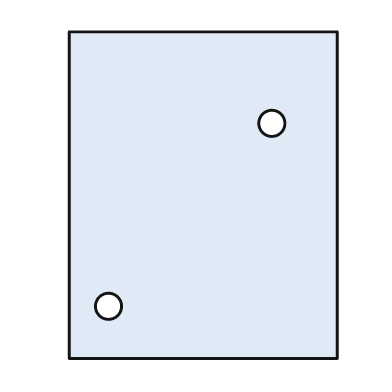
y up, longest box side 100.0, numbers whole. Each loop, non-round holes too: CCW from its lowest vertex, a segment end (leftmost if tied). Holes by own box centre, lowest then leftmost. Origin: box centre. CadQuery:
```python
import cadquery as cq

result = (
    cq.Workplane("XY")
    .moveTo(-41.0, -50.0)
    .lineTo(41.0, -50.0)
    .lineTo(41.0, 50.0)
    .lineTo(-41.0, 50.0)
    .close()
    .moveTo(-29.0, -34.0)
    .circle(4.0)
    .moveTo(21.0, 22.0)
    .circle(4.0)
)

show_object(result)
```